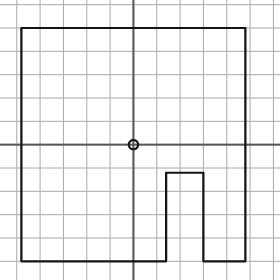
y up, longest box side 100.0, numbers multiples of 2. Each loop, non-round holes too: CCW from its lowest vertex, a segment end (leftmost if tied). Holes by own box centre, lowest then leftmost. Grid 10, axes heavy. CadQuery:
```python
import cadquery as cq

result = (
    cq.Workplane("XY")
    .moveTo(-48.0, -50.0)
    .lineTo(14.0, -50.0)
    .lineTo(14.0, -12.0)
    .lineTo(30.0, -12.0)
    .lineTo(30.0, -50.0)
    .lineTo(48.0, -50.0)
    .lineTo(48.0, 50.0)
    .lineTo(-48.0, 50.0)
    .close()
    .moveTo(0.0, 0.0)
    .circle(2.0)
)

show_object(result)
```